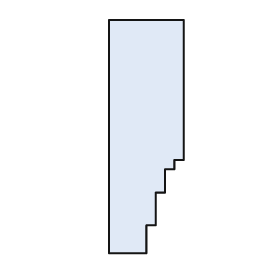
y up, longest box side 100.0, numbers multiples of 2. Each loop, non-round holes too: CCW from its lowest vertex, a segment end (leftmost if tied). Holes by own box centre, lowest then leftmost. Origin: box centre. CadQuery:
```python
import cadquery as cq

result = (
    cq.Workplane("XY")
    .moveTo(-16.0, -50.0)
    .lineTo(0.0, -50.0)
    .lineTo(0.0, -38.0)
    .lineTo(4.0, -38.0)
    .lineTo(4.0, -24.0)
    .lineTo(8.0, -24.0)
    .lineTo(8.0, -14.0)
    .lineTo(12.0, -14.0)
    .lineTo(12.0, -10.0)
    .lineTo(16.0, -10.0)
    .lineTo(16.0, 50.0)
    .lineTo(-16.0, 50.0)
    .close()
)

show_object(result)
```